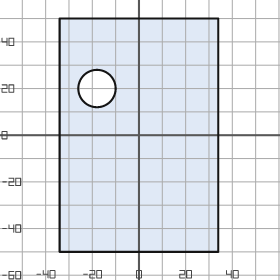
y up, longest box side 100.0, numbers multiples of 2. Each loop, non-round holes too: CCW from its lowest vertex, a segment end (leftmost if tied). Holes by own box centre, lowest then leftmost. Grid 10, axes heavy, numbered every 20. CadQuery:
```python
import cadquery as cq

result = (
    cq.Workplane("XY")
    .moveTo(-34.0, -50.0)
    .lineTo(34.0, -50.0)
    .lineTo(34.0, 50.0)
    .lineTo(-34.0, 50.0)
    .close()
    .moveTo(-18.0, 20.0)
    .circle(8.0)
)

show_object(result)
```